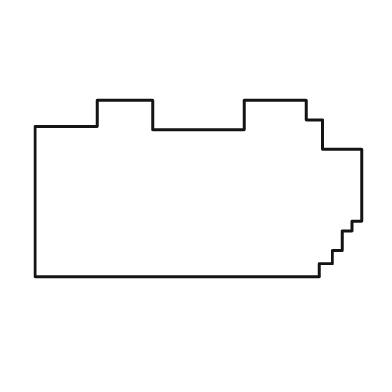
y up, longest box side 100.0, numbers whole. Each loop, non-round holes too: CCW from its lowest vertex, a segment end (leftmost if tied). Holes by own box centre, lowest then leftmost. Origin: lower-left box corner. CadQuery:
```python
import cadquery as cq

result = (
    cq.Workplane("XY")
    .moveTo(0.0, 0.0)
    .lineTo(87.0, 0.0)
    .lineTo(87.0, 4.0)
    .lineTo(91.0, 4.0)
    .lineTo(91.0, 8.0)
    .lineTo(94.0, 8.0)
    .lineTo(94.0, 14.0)
    .lineTo(97.0, 14.0)
    .lineTo(97.0, 17.0)
    .lineTo(100.0, 17.0)
    .lineTo(100.0, 39.0)
    .lineTo(88.0, 39.0)
    .lineTo(88.0, 48.0)
    .lineTo(83.0, 48.0)
    .lineTo(83.0, 54.0)
    .lineTo(64.0, 54.0)
    .lineTo(64.0, 45.0)
    .lineTo(36.0, 45.0)
    .lineTo(36.0, 54.0)
    .lineTo(19.0, 54.0)
    .lineTo(19.0, 46.0)
    .lineTo(0.0, 46.0)
    .close()
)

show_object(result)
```